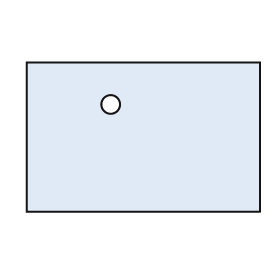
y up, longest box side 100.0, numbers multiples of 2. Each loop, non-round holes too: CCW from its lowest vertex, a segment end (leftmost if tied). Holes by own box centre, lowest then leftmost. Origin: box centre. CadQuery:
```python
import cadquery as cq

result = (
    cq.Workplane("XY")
    .moveTo(-50.0, -32.0)
    .lineTo(50.0, -32.0)
    .lineTo(50.0, 32.0)
    .lineTo(-50.0, 32.0)
    .close()
    .moveTo(-14.0, 14.0)
    .circle(4.0)
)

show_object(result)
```